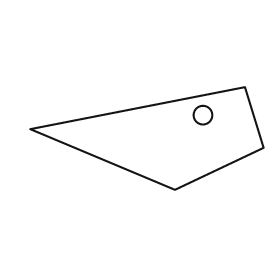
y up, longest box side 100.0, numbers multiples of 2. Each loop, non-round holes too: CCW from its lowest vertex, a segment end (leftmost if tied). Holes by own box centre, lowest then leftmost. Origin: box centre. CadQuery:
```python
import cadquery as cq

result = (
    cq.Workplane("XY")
    .moveTo(12.0, -22.0)
    .lineTo(50.0, -4.0)
    .lineTo(42.0, 22.0)
    .lineTo(-50.0, 4.0)
    .close()
    .moveTo(24.0, 10.0)
    .circle(4.0)
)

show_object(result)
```